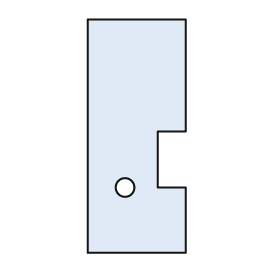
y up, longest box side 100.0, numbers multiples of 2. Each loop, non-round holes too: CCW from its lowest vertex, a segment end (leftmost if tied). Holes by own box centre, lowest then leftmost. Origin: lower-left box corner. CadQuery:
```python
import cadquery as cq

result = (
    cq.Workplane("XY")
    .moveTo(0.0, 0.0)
    .lineTo(42.0, 0.0)
    .lineTo(42.0, 28.0)
    .lineTo(30.0, 28.0)
    .lineTo(30.0, 52.0)
    .lineTo(42.0, 52.0)
    .lineTo(42.0, 100.0)
    .lineTo(0.0, 100.0)
    .close()
    .moveTo(16.0, 28.0)
    .circle(4.0)
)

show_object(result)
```